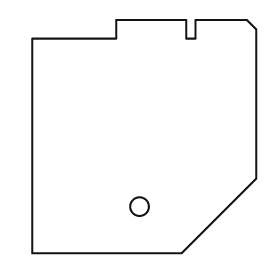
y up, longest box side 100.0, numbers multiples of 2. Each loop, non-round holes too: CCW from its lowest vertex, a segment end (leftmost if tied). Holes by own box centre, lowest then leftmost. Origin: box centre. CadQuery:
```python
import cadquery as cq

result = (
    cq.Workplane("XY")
    .moveTo(-48.0, -50.0)
    .lineTo(16.0, -50.0)
    .lineTo(48.0, -18.0)
    .lineTo(48.0, 46.0)
    .lineTo(44.0, 50.0)
    .lineTo(22.0, 50.0)
    .lineTo(22.0, 42.0)
    .lineTo(18.0, 42.0)
    .lineTo(18.0, 50.0)
    .lineTo(-12.0, 50.0)
    .lineTo(-12.0, 42.0)
    .lineTo(-48.0, 42.0)
    .close()
    .moveTo(-2.0, -30.0)
    .circle(4.0)
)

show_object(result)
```